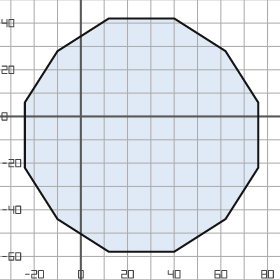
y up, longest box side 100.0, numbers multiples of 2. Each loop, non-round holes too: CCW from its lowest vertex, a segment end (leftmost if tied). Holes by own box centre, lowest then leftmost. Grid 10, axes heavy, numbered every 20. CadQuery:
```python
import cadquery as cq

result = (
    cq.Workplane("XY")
    .moveTo(12.0, -58.0)
    .lineTo(40.0, -58.0)
    .lineTo(62.0, -44.0)
    .lineTo(76.0, -22.0)
    .lineTo(76.0, 6.0)
    .lineTo(62.0, 28.0)
    .lineTo(40.0, 42.0)
    .lineTo(12.0, 42.0)
    .lineTo(-10.0, 28.0)
    .lineTo(-24.0, 6.0)
    .lineTo(-24.0, -22.0)
    .lineTo(-10.0, -44.0)
    .close()
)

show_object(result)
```